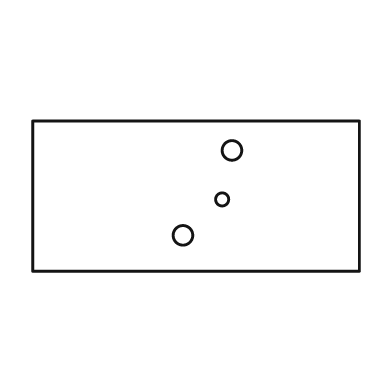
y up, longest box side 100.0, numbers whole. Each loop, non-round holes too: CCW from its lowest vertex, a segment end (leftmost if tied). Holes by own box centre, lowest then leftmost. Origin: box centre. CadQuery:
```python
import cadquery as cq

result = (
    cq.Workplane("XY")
    .moveTo(-50.0, -23.0)
    .lineTo(50.0, -23.0)
    .lineTo(50.0, 23.0)
    .lineTo(-50.0, 23.0)
    .close()
    .moveTo(-4.0, -12.0)
    .circle(3.0)
    .moveTo(8.0, -1.0)
    .circle(2.0)
    .moveTo(11.0, 14.0)
    .circle(3.0)
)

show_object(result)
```